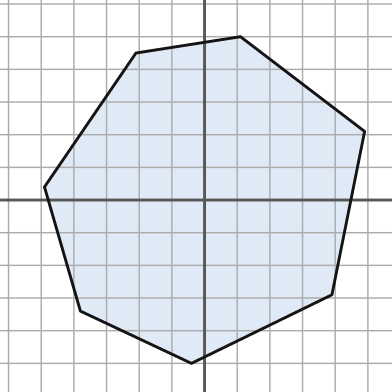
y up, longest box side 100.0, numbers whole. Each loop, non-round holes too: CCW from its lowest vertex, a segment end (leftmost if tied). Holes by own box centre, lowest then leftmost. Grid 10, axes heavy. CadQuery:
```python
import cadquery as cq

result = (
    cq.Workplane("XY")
    .moveTo(-4.0, -50.0)
    .lineTo(39.0, -29.0)
    .lineTo(49.0, 21.0)
    .lineTo(11.0, 50.0)
    .lineTo(-21.0, 45.0)
    .lineTo(-49.0, 4.0)
    .lineTo(-38.0, -34.0)
    .close()
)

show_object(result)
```